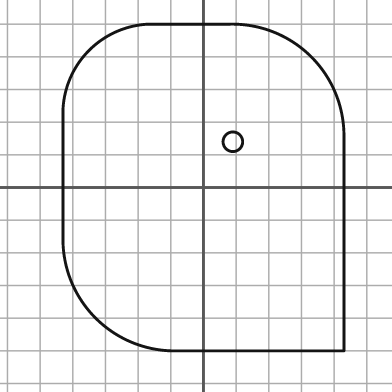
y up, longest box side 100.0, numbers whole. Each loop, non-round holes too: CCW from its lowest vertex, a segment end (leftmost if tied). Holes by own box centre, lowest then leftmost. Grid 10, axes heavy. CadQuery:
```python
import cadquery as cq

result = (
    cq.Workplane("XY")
    .moveTo(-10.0, -50.0)
    .lineTo(43.0, -50.0)
    .lineTo(43.0, 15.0)
    .threePointArc((33.0, 40.0), (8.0, 50.0))
    .lineTo(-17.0, 50.0)
    .threePointArc((-35.0, 42.0), (-43.0, 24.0))
    .lineTo(-43.0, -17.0)
    .threePointArc((-33.0, -40.0), (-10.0, -50.0))
    .close()
    .moveTo(9.0, 14.0)
    .circle(3.0)
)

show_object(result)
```